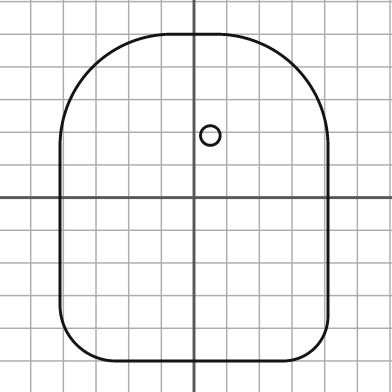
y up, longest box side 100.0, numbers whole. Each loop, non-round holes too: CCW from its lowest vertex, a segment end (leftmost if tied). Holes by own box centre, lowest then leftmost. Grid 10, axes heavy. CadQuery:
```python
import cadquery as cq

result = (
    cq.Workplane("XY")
    .moveTo(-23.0, -50.0)
    .lineTo(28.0, -50.0)
    .threePointArc((37.0, -46.0), (41.0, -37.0))
    .lineTo(41.0, 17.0)
    .threePointArc((31.0, 40.0), (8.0, 50.0))
    .lineTo(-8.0, 50.0)
    .threePointArc((-31.0, 40.0), (-41.0, 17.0))
    .lineTo(-41.0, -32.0)
    .threePointArc((-36.0, -45.0), (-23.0, -50.0))
    .close()
    .moveTo(5.0, 19.0)
    .circle(3.0)
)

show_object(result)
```